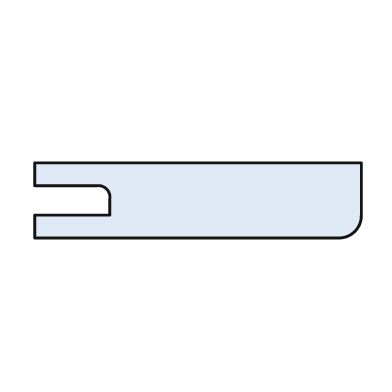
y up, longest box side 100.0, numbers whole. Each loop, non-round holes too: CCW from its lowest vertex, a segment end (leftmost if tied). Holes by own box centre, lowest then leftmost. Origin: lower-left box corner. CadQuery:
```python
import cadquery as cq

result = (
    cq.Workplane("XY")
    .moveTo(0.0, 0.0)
    .lineTo(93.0, 0.0)
    .threePointArc((98.0, 2.0), (100.0, 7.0))
    .lineTo(100.0, 23.0)
    .lineTo(0.0, 23.0)
    .lineTo(0.0, 16.0)
    .lineTo(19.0, 16.0)
    .threePointArc((22.0, 15.0), (23.0, 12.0))
    .lineTo(23.0, 7.0)
    .lineTo(0.0, 7.0)
    .close()
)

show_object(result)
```